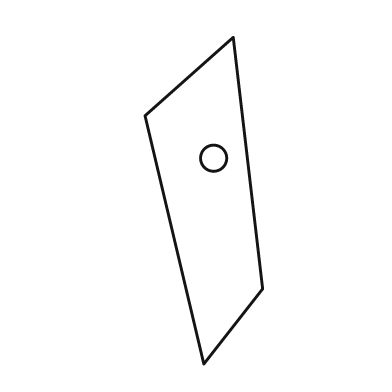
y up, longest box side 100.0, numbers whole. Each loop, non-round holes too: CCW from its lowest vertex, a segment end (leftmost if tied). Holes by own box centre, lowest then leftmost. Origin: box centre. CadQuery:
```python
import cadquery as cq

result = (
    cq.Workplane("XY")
    .moveTo(0.0, -50.0)
    .lineTo(18.0, -27.0)
    .lineTo(9.0, 50.0)
    .lineTo(-18.0, 26.0)
    .close()
    .moveTo(3.0, 13.0)
    .circle(4.0)
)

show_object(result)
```